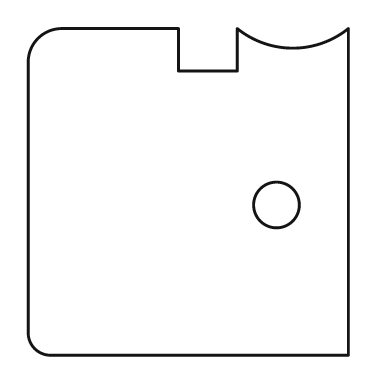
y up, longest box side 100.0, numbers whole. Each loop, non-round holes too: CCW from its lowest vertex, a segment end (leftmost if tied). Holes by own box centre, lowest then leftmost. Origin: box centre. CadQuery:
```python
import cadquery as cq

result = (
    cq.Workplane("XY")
    .moveTo(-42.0, -50.0)
    .lineTo(49.0, -50.0)
    .lineTo(49.0, 50.0)
    .threePointArc((32.0, 44.0), (15.0, 50.0))
    .lineTo(15.0, 37.0)
    .lineTo(-3.0, 37.0)
    .lineTo(-3.0, 50.0)
    .lineTo(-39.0, 50.0)
    .threePointArc((-46.0, 47.0), (-49.0, 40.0))
    .lineTo(-49.0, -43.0)
    .threePointArc((-47.0, -48.0), (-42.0, -50.0))
    .close()
    .moveTo(27.0, -4.0)
    .circle(7.0)
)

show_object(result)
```